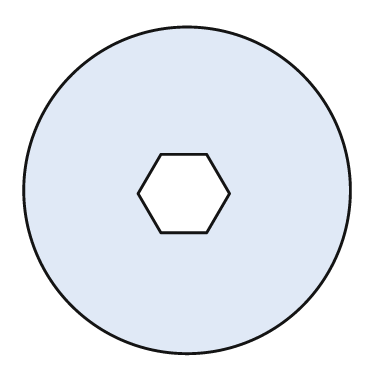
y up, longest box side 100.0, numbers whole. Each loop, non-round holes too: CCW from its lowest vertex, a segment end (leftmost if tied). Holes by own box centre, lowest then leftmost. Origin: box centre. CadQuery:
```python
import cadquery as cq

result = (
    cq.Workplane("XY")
    .moveTo(0.0, 0.0)
    .circle(50.0)
    .moveTo(-8.0, -13.0)
    .lineTo(6.0, -13.0)
    .lineTo(13.0, -1.0)
    .lineTo(6.0, 11.0)
    .lineTo(-8.0, 11.0)
    .lineTo(-15.0, -1.0)
    .close()
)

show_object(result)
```